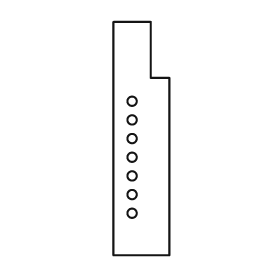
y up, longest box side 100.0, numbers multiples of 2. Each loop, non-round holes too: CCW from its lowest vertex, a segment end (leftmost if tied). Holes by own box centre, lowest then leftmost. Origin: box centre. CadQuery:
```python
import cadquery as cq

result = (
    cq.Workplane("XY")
    .moveTo(-12.0, -50.0)
    .lineTo(12.0, -50.0)
    .lineTo(12.0, 26.0)
    .lineTo(4.0, 26.0)
    .lineTo(4.0, 50.0)
    .lineTo(-12.0, 50.0)
    .close()
    .moveTo(-4.0, -32.0)
    .circle(2.0)
    .moveTo(-4.0, -24.0)
    .circle(2.0)
    .moveTo(-4.0, -16.0)
    .circle(2.0)
    .moveTo(-4.0, -8.0)
    .circle(2.0)
    .moveTo(-4.0, 0.0)
    .circle(2.0)
    .moveTo(-4.0, 8.0)
    .circle(2.0)
    .moveTo(-4.0, 16.0)
    .circle(2.0)
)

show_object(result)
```